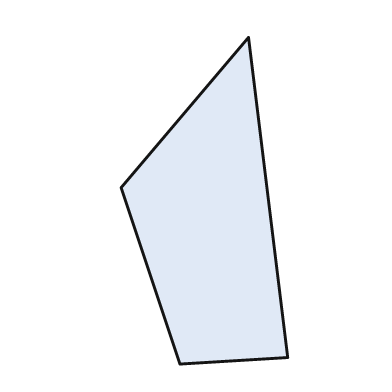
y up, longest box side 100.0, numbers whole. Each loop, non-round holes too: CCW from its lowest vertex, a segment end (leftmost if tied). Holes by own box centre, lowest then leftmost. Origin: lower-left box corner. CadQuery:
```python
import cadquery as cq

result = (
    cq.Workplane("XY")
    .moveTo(18.0, 0.0)
    .lineTo(51.0, 2.0)
    .lineTo(39.0, 100.0)
    .lineTo(0.0, 54.0)
    .close()
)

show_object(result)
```